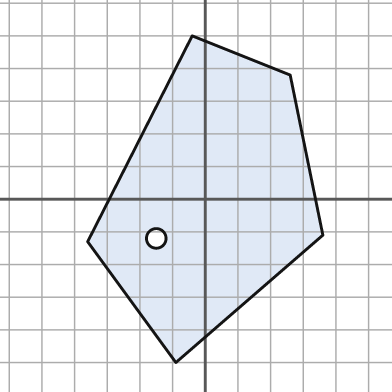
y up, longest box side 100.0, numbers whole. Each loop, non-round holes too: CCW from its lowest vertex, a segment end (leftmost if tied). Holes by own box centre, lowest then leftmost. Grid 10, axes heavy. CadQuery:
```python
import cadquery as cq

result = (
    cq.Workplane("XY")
    .moveTo(-9.0, -50.0)
    .lineTo(36.0, -11.0)
    .lineTo(26.0, 38.0)
    .lineTo(-4.0, 50.0)
    .lineTo(-36.0, -13.0)
    .close()
    .moveTo(-15.0, -12.0)
    .circle(3.0)
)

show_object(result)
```